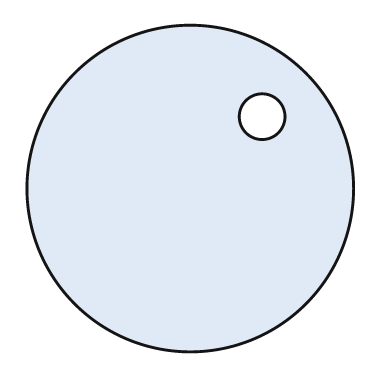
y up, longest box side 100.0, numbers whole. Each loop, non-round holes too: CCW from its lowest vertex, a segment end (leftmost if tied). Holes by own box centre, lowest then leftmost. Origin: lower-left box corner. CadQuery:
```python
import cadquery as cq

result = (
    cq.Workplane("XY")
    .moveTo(50.0, 50.0)
    .circle(50.0)
    .moveTo(72.0, 72.0)
    .circle(7.0)
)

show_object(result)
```